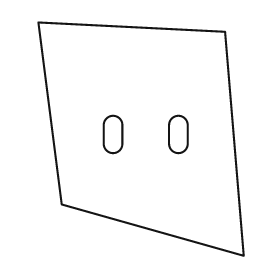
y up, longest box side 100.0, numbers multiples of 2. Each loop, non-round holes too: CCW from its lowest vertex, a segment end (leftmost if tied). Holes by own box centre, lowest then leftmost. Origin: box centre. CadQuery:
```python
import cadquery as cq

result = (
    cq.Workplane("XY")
    .moveTo(44.0, -50.0)
    .lineTo(36.0, 46.0)
    .lineTo(-44.0, 50.0)
    .lineTo(-34.0, -28.0)
    .close()
    .moveTo(-16.0, -2.0)
    .threePointArc((-12.0, -6.0), (-8.0, -2.0))
    .lineTo(-8.0, 6.0)
    .threePointArc((-12.0, 10.0), (-16.0, 6.0))
    .close()
    .moveTo(12.0, -2.0)
    .threePointArc((16.0, -6.0), (20.0, -2.0))
    .lineTo(20.0, 6.0)
    .threePointArc((16.0, 10.0), (12.0, 6.0))
    .close()
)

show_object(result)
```